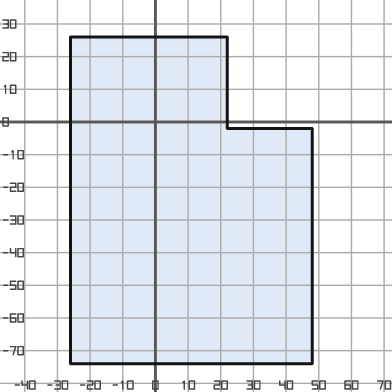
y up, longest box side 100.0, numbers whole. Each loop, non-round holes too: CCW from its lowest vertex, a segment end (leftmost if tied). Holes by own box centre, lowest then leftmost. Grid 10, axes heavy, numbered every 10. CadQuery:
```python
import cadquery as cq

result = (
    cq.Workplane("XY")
    .moveTo(-26.0, -74.0)
    .lineTo(48.0, -74.0)
    .lineTo(48.0, -2.0)
    .lineTo(22.0, -2.0)
    .lineTo(22.0, 26.0)
    .lineTo(-26.0, 26.0)
    .close()
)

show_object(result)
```